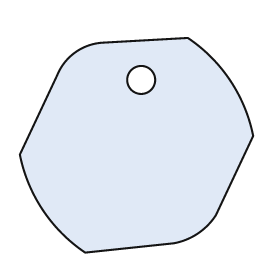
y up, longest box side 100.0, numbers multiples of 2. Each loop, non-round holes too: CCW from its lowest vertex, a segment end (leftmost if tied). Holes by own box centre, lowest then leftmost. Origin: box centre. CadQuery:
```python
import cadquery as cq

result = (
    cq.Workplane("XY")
    .moveTo(-22.0, -46.0)
    .lineTo(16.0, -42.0)
    .threePointArc((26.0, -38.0), (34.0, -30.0))
    .lineTo(50.0, 4.0)
    .threePointArc((40.0, 28.0), (22.0, 46.0))
    .lineTo(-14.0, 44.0)
    .threePointArc((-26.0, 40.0), (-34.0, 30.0))
    .lineTo(-50.0, -4.0)
    .threePointArc((-40.0, -28.0), (-22.0, -46.0))
    .close()
    .moveTo(2.0, 28.0)
    .circle(6.0)
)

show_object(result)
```